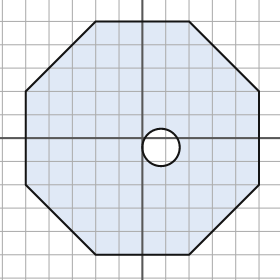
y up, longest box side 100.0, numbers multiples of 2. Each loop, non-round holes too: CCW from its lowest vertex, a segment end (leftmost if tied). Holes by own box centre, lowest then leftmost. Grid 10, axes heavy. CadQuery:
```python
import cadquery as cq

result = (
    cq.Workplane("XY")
    .moveTo(-20.0, -50.0)
    .lineTo(20.0, -50.0)
    .lineTo(50.0, -20.0)
    .lineTo(50.0, 20.0)
    .lineTo(20.0, 50.0)
    .lineTo(-20.0, 50.0)
    .lineTo(-50.0, 20.0)
    .lineTo(-50.0, -20.0)
    .close()
    .moveTo(8.0, -4.0)
    .circle(8.0)
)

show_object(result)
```